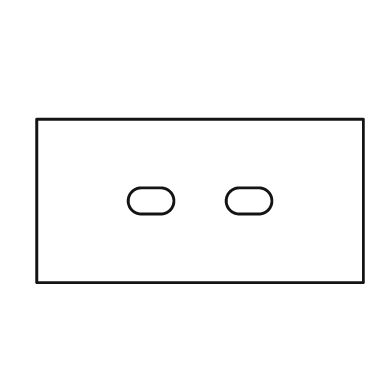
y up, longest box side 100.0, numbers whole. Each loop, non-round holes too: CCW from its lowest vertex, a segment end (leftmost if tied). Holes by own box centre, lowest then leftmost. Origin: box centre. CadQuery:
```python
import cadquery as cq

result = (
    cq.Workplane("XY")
    .moveTo(-50.0, -25.0)
    .lineTo(50.0, -25.0)
    .lineTo(50.0, 25.0)
    .lineTo(-50.0, 25.0)
    .close()
    .moveTo(-18.0, -4.0)
    .lineTo(-12.0, -4.0)
    .threePointArc((-8.0, 0.0), (-12.0, 4.0))
    .lineTo(-18.0, 4.0)
    .threePointArc((-22.0, 0.0), (-18.0, -4.0))
    .close()
    .moveTo(12.0, -4.0)
    .lineTo(18.0, -4.0)
    .threePointArc((22.0, 0.0), (18.0, 4.0))
    .lineTo(12.0, 4.0)
    .threePointArc((8.0, 0.0), (12.0, -4.0))
    .close()
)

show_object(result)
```